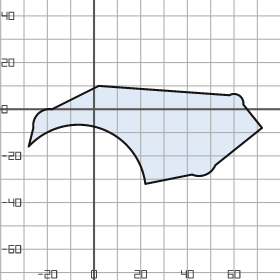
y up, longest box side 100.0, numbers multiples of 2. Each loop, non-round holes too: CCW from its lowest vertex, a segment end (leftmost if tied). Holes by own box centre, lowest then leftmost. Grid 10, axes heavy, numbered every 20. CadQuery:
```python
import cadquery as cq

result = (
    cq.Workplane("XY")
    .moveTo(22.0, -32.0)
    .lineTo(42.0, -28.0)
    .threePointArc((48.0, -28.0), (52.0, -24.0))
    .lineTo(72.0, -8.0)
    .lineTo(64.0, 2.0)
    .threePointArc((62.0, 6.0), (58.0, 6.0))
    .lineTo(2.0, 10.0)
    .lineTo(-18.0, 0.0)
    .threePointArc((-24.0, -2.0), (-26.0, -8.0))
    .lineTo(-28.0, -16.0)
    .threePointArc((2.0, -8.0), (22.0, -32.0))
    .close()
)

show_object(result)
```